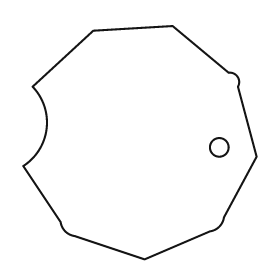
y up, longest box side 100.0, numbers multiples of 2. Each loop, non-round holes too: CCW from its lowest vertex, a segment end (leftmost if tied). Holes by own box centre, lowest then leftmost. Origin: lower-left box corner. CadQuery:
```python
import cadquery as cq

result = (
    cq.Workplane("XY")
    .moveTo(52.0, 0.0)
    .lineTo(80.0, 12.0)
    .threePointArc((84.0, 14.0), (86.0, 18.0))
    .lineTo(100.0, 44.0)
    .lineTo(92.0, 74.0)
    .threePointArc((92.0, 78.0), (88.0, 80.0))
    .lineTo(64.0, 100.0)
    .lineTo(30.0, 98.0)
    .lineTo(4.0, 74.0)
    .threePointArc((10.0, 56.0), (0.0, 40.0))
    .lineTo(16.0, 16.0)
    .threePointArc((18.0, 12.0), (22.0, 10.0))
    .close()
    .moveTo(84.0, 48.0)
    .circle(4.0)
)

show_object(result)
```